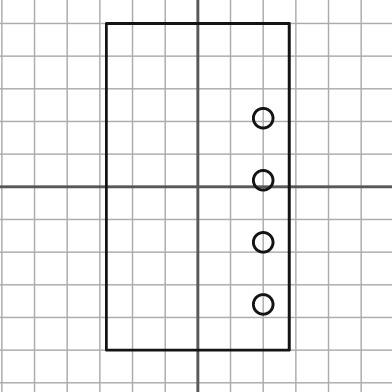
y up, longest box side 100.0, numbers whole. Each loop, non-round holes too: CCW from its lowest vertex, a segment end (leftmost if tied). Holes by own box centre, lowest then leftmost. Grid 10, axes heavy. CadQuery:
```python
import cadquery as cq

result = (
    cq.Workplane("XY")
    .moveTo(-28.0, -50.0)
    .lineTo(28.0, -50.0)
    .lineTo(28.0, 50.0)
    .lineTo(-28.0, 50.0)
    .close()
    .moveTo(20.0, -36.0)
    .circle(3.0)
    .moveTo(20.0, -17.0)
    .circle(3.0)
    .moveTo(20.0, 2.0)
    .circle(3.0)
    .moveTo(20.0, 21.0)
    .circle(3.0)
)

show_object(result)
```